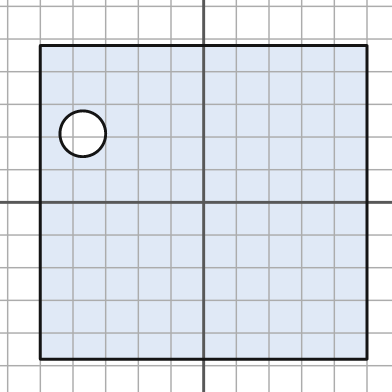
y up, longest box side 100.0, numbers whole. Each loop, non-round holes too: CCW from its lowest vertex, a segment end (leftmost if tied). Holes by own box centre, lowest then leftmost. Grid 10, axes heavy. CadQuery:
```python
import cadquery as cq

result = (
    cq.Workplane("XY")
    .moveTo(-50.0, -48.0)
    .lineTo(50.0, -48.0)
    .lineTo(50.0, 48.0)
    .lineTo(-50.0, 48.0)
    .close()
    .moveTo(-37.0, 21.0)
    .circle(7.0)
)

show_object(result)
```